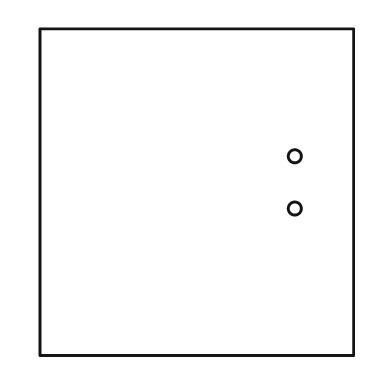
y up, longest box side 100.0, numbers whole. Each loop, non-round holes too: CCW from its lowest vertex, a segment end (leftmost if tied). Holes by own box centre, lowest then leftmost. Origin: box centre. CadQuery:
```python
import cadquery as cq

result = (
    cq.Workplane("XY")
    .moveTo(-48.0, -50.0)
    .lineTo(48.0, -50.0)
    .lineTo(48.0, 50.0)
    .lineTo(-48.0, 50.0)
    .close()
    .moveTo(30.0, -5.0)
    .circle(2.0)
    .moveTo(30.0, 11.0)
    .circle(2.0)
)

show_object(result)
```